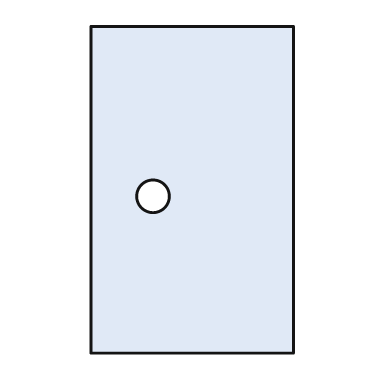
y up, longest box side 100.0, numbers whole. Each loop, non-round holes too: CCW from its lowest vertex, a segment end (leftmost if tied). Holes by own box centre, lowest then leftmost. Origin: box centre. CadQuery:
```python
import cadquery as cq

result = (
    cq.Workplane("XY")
    .moveTo(-31.0, -50.0)
    .lineTo(31.0, -50.0)
    .lineTo(31.0, 50.0)
    .lineTo(-31.0, 50.0)
    .close()
    .moveTo(-12.0, -2.0)
    .circle(5.0)
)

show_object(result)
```